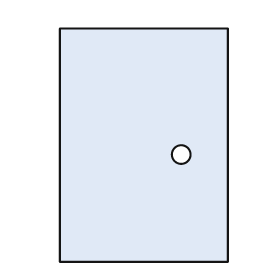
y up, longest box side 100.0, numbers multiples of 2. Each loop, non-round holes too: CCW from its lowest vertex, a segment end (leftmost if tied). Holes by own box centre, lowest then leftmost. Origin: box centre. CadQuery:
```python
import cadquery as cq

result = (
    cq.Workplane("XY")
    .moveTo(-36.0, -50.0)
    .lineTo(36.0, -50.0)
    .lineTo(36.0, 50.0)
    .lineTo(-36.0, 50.0)
    .close()
    .moveTo(16.0, -4.0)
    .circle(4.0)
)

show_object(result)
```